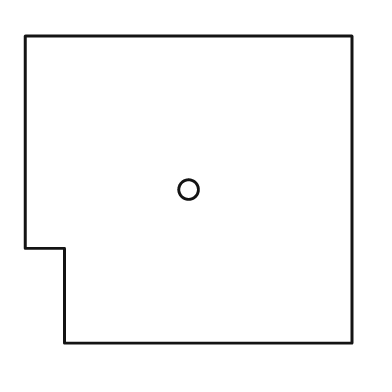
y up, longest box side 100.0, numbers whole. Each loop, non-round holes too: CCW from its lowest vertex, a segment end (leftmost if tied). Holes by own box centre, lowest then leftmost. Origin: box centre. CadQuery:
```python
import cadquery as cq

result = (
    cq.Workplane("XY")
    .moveTo(-38.0, -47.0)
    .lineTo(50.0, -47.0)
    .lineTo(50.0, 47.0)
    .lineTo(-50.0, 47.0)
    .lineTo(-50.0, -18.0)
    .lineTo(-38.0, -18.0)
    .close()
    .moveTo(0.0, 0.0)
    .circle(3.0)
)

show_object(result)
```